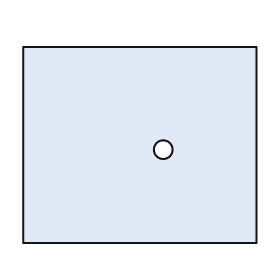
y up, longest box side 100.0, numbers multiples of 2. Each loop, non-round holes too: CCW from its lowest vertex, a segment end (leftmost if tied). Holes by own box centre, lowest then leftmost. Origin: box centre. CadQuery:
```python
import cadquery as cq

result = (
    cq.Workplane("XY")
    .moveTo(-50.0, -42.0)
    .lineTo(50.0, -42.0)
    .lineTo(50.0, 42.0)
    .lineTo(-50.0, 42.0)
    .close()
    .moveTo(10.0, -2.0)
    .circle(4.0)
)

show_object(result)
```